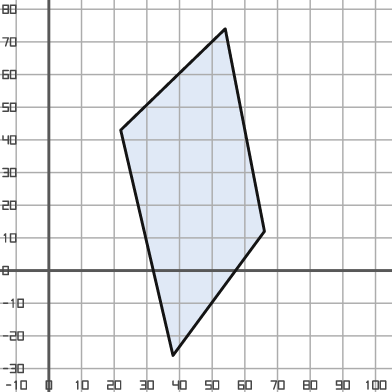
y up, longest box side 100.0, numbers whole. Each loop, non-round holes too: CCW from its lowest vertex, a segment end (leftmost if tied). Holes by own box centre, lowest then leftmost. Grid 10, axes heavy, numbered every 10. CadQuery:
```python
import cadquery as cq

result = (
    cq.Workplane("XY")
    .moveTo(38.0, -26.0)
    .lineTo(66.0, 12.0)
    .lineTo(54.0, 74.0)
    .lineTo(22.0, 43.0)
    .close()
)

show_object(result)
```